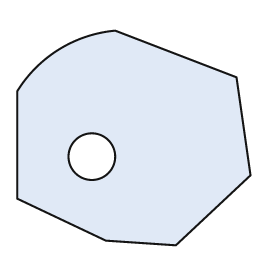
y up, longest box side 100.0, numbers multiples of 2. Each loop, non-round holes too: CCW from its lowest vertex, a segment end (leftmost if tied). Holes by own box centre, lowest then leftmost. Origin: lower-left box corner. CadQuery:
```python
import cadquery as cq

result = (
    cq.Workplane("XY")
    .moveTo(68.0, 0.0)
    .lineTo(100.0, 30.0)
    .lineTo(94.0, 72.0)
    .lineTo(42.0, 92.0)
    .threePointArc((18.0, 84.0), (0.0, 66.0))
    .lineTo(0.0, 20.0)
    .lineTo(38.0, 2.0)
    .close()
    .moveTo(32.0, 38.0)
    .circle(10.0)
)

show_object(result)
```